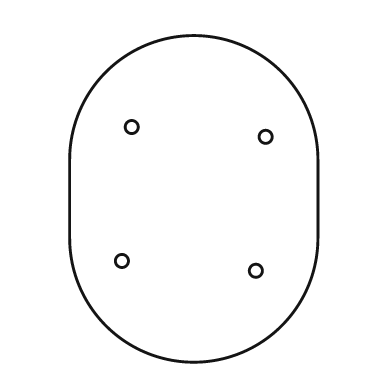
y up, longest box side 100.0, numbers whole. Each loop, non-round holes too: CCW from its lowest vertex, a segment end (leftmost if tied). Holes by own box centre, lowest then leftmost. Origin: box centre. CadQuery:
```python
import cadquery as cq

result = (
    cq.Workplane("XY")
    .moveTo(-38.0, -12.0)
    .threePointArc((0.0, -50.0), (38.0, -12.0))
    .lineTo(38.0, 12.0)
    .threePointArc((0.0, 50.0), (-38.0, 12.0))
    .close()
    .moveTo(19.0, -22.0)
    .circle(2.0)
    .moveTo(-22.0, -19.0)
    .circle(2.0)
    .moveTo(22.0, 19.0)
    .circle(2.0)
    .moveTo(-19.0, 22.0)
    .circle(2.0)
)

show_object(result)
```